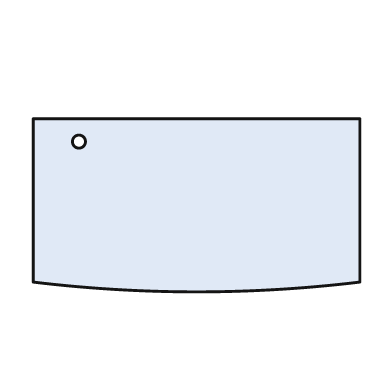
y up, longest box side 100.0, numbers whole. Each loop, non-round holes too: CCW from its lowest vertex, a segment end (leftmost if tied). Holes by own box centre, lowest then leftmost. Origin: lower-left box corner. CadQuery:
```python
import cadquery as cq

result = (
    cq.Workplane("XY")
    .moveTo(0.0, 3.0)
    .threePointArc((50.0, 0.0), (100.0, 3.0))
    .lineTo(100.0, 53.0)
    .lineTo(0.0, 53.0)
    .close()
    .moveTo(14.0, 46.0)
    .circle(2.0)
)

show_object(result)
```